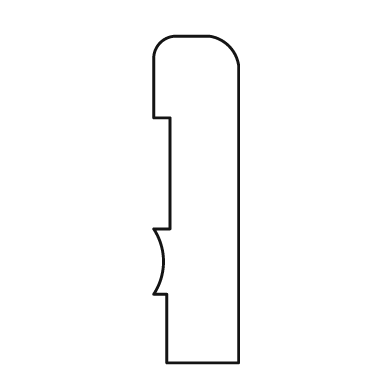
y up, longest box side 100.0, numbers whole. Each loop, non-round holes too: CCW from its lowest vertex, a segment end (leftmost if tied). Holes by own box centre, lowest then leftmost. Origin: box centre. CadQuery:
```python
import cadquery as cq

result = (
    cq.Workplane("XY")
    .moveTo(-9.0, -50.0)
    .lineTo(13.0, -50.0)
    .lineTo(13.0, 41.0)
    .threePointArc((10.0, 47.0), (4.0, 50.0))
    .lineTo(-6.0, 50.0)
    .threePointArc((-11.0, 48.0), (-13.0, 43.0))
    .lineTo(-13.0, 25.0)
    .lineTo(-8.0, 25.0)
    .lineTo(-8.0, -9.0)
    .lineTo(-13.0, -9.0)
    .threePointArc((-10.0, -19.0), (-13.0, -29.0))
    .lineTo(-9.0, -29.0)
    .close()
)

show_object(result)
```